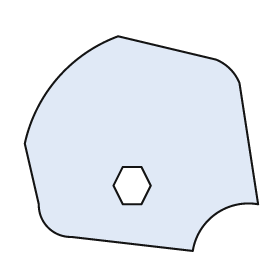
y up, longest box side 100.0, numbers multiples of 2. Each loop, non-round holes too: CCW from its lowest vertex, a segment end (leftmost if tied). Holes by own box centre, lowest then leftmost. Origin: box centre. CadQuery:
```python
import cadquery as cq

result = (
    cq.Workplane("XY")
    .moveTo(22.0, -46.0)
    .threePointArc((32.0, -30.0), (50.0, -26.0))
    .lineTo(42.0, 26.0)
    .threePointArc((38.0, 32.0), (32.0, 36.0))
    .lineTo(-10.0, 46.0)
    .threePointArc((-36.0, 28.0), (-50.0, 0.0))
    .lineTo(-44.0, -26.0)
    .threePointArc((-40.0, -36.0), (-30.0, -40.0))
    .close()
    .moveTo(-8.0, -26.0)
    .lineTo(0.0, -26.0)
    .lineTo(4.0, -18.0)
    .lineTo(0.0, -10.0)
    .lineTo(-8.0, -10.0)
    .lineTo(-12.0, -18.0)
    .close()
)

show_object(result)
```